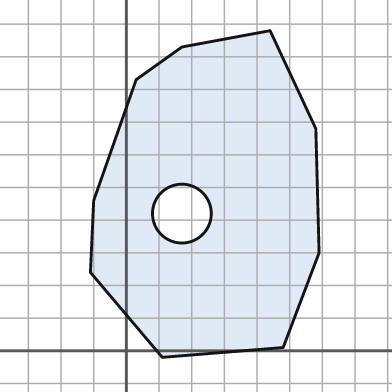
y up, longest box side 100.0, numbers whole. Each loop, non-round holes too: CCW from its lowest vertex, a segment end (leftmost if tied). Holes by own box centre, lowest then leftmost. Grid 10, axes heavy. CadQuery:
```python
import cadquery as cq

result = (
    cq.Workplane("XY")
    .moveTo(11.0, -2.0)
    .lineTo(48.0, 1.0)
    .lineTo(59.0, 30.0)
    .lineTo(58.0, 68.0)
    .lineTo(44.0, 98.0)
    .lineTo(17.0, 93.0)
    .lineTo(3.0, 83.0)
    .lineTo(-10.0, 46.0)
    .lineTo(-11.0, 24.0)
    .close()
    .moveTo(17.0, 42.0)
    .circle(9.0)
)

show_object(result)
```